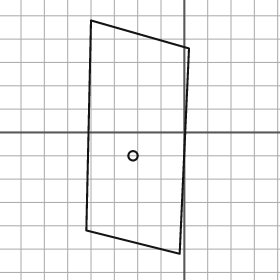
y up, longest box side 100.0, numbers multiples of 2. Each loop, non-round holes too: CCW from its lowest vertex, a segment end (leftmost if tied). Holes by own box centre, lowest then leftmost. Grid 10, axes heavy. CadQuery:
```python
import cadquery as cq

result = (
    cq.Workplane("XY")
    .moveTo(-2.0, -52.0)
    .lineTo(2.0, 36.0)
    .lineTo(-40.0, 48.0)
    .lineTo(-42.0, -42.0)
    .close()
    .moveTo(-22.0, -10.0)
    .circle(2.0)
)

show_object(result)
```